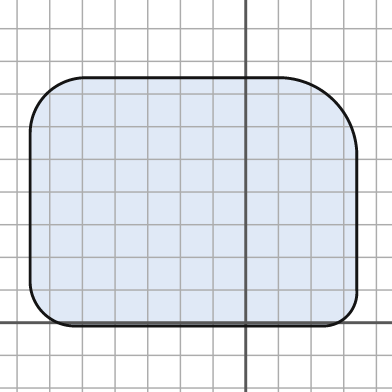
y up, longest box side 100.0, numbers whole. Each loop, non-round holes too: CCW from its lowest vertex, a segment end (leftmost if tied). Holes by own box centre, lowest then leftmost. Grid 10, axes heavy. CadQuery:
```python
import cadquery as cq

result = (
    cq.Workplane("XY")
    .moveTo(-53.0, -1.0)
    .lineTo(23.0, -1.0)
    .threePointArc((31.0, 2.0), (34.0, 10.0))
    .lineTo(34.0, 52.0)
    .threePointArc((27.0, 68.0), (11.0, 75.0))
    .lineTo(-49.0, 75.0)
    .threePointArc((-61.0, 70.0), (-66.0, 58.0))
    .lineTo(-66.0, 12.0)
    .threePointArc((-62.0, 3.0), (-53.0, -1.0))
    .close()
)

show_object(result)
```